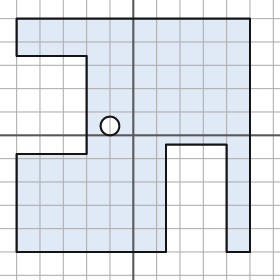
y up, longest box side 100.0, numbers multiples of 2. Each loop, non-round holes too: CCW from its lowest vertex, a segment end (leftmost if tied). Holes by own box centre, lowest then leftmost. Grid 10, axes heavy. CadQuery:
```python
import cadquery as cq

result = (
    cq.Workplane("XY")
    .moveTo(-50.0, -50.0)
    .lineTo(14.0, -50.0)
    .lineTo(14.0, -4.0)
    .lineTo(40.0, -4.0)
    .lineTo(40.0, -50.0)
    .lineTo(50.0, -50.0)
    .lineTo(50.0, 50.0)
    .lineTo(-50.0, 50.0)
    .lineTo(-50.0, 34.0)
    .lineTo(-20.0, 34.0)
    .lineTo(-20.0, -8.0)
    .lineTo(-50.0, -8.0)
    .close()
    .moveTo(-10.0, 4.0)
    .circle(4.0)
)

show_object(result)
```